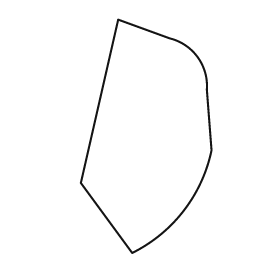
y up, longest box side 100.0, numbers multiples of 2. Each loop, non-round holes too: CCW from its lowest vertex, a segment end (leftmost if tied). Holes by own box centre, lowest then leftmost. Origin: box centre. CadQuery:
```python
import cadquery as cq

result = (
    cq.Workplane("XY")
    .moveTo(-6.0, -50.0)
    .threePointArc((16.0, -32.0), (28.0, -6.0))
    .lineTo(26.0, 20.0)
    .threePointArc((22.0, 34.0), (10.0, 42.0))
    .lineTo(-12.0, 50.0)
    .lineTo(-28.0, -20.0)
    .close()
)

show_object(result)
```